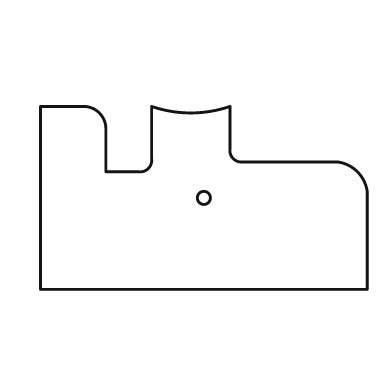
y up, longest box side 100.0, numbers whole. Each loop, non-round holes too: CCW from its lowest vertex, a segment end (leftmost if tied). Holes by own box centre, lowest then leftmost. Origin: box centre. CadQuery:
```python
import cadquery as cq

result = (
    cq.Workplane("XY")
    .moveTo(-50.0, -28.0)
    .lineTo(50.0, -28.0)
    .lineTo(50.0, 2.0)
    .threePointArc((47.0, 8.0), (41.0, 11.0))
    .lineTo(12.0, 11.0)
    .threePointArc((9.0, 12.0), (8.0, 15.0))
    .lineTo(8.0, 28.0)
    .threePointArc((-4.0, 26.0), (-16.0, 28.0))
    .lineTo(-16.0, 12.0)
    .threePointArc((-17.0, 9.0), (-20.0, 8.0))
    .lineTo(-30.0, 8.0)
    .lineTo(-30.0, 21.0)
    .threePointArc((-32.0, 26.0), (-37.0, 28.0))
    .lineTo(-50.0, 28.0)
    .close()
    .moveTo(0.0, 0.0)
    .circle(2.0)
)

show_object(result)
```